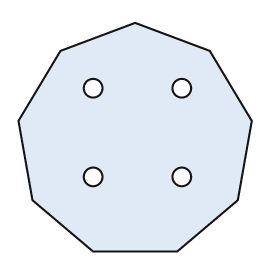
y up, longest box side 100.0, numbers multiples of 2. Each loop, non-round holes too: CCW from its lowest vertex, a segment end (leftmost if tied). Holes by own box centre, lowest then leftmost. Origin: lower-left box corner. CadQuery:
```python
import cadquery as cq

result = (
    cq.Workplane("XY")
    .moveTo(32.0, 0.0)
    .lineTo(68.0, 0.0)
    .lineTo(94.0, 22.0)
    .lineTo(100.0, 56.0)
    .lineTo(82.0, 86.0)
    .lineTo(50.0, 98.0)
    .lineTo(18.0, 86.0)
    .lineTo(0.0, 56.0)
    .lineTo(6.0, 22.0)
    .close()
    .moveTo(32.0, 32.0)
    .circle(4.0)
    .moveTo(70.0, 32.0)
    .circle(4.0)
    .moveTo(32.0, 70.0)
    .circle(4.0)
    .moveTo(70.0, 70.0)
    .circle(4.0)
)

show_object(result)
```